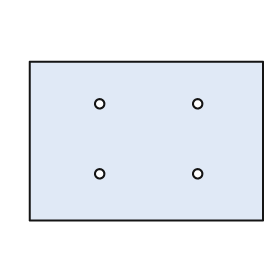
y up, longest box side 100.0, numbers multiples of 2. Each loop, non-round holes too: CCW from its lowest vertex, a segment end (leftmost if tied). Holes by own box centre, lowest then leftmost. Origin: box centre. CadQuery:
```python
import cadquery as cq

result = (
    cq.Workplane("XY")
    .moveTo(-50.0, -34.0)
    .lineTo(50.0, -34.0)
    .lineTo(50.0, 34.0)
    .lineTo(-50.0, 34.0)
    .close()
    .moveTo(-20.0, -14.0)
    .circle(2.0)
    .moveTo(22.0, -14.0)
    .circle(2.0)
    .moveTo(-20.0, 16.0)
    .circle(2.0)
    .moveTo(22.0, 16.0)
    .circle(2.0)
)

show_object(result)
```